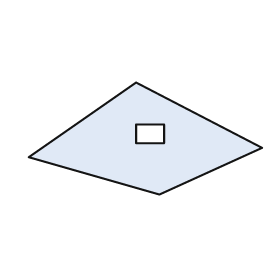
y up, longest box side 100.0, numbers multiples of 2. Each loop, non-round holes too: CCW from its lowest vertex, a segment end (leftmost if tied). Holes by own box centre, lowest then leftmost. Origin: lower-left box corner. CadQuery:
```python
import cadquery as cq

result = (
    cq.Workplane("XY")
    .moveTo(56.0, 0.0)
    .lineTo(100.0, 20.0)
    .lineTo(46.0, 48.0)
    .lineTo(0.0, 16.0)
    .close()
    .moveTo(46.0, 22.0)
    .lineTo(58.0, 22.0)
    .lineTo(58.0, 30.0)
    .lineTo(46.0, 30.0)
    .close()
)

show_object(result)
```